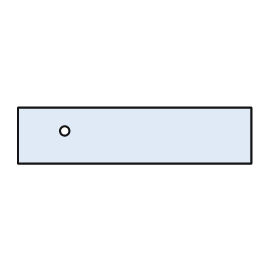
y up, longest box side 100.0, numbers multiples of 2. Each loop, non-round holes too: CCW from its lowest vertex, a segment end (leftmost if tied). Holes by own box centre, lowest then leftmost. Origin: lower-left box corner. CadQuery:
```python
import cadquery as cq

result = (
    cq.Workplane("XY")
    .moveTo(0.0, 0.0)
    .lineTo(100.0, 0.0)
    .lineTo(100.0, 24.0)
    .lineTo(0.0, 24.0)
    .close()
    .moveTo(20.0, 14.0)
    .circle(2.0)
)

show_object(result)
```